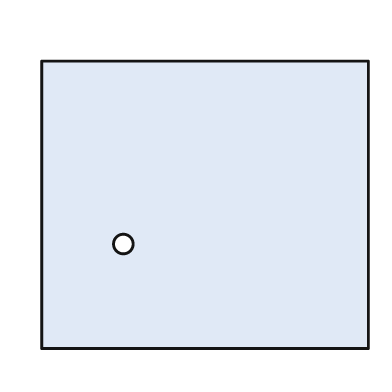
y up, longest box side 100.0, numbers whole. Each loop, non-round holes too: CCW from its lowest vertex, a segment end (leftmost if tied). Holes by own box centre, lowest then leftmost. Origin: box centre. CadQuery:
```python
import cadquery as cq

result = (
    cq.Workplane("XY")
    .moveTo(-50.0, -44.0)
    .lineTo(50.0, -44.0)
    .lineTo(50.0, 44.0)
    .lineTo(-50.0, 44.0)
    .close()
    .moveTo(-25.0, -12.0)
    .circle(3.0)
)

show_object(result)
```